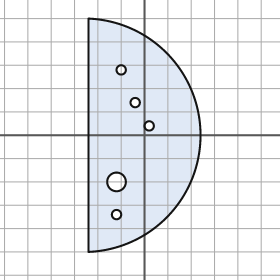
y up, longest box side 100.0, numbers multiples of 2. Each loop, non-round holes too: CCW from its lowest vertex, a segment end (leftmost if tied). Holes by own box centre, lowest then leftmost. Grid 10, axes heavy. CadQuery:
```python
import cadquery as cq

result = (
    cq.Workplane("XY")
    .moveTo(-24.0, -50.0)
    .threePointArc((24.0, 0.0), (-24.0, 50.0))
    .close()
    .moveTo(-12.0, -34.0)
    .circle(2.0)
    .moveTo(-12.0, -20.0)
    .circle(4.0)
    .moveTo(2.0, 4.0)
    .circle(2.0)
    .moveTo(-4.0, 14.0)
    .circle(2.0)
    .moveTo(-10.0, 28.0)
    .circle(2.0)
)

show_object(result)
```